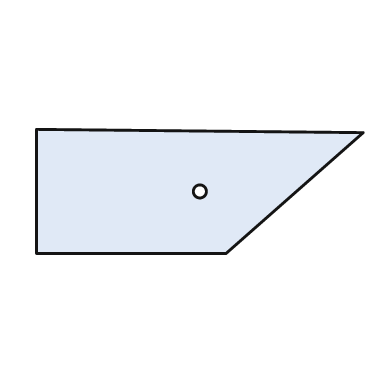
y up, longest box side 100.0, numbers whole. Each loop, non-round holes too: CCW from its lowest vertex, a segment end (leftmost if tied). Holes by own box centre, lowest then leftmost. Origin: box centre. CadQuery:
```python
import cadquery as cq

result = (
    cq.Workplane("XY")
    .moveTo(-50.0, -19.0)
    .lineTo(8.0, -19.0)
    .lineTo(50.0, 18.0)
    .lineTo(-50.0, 19.0)
    .close()
    .moveTo(0.0, 0.0)
    .circle(2.0)
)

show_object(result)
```